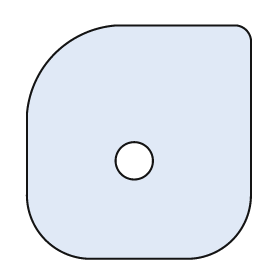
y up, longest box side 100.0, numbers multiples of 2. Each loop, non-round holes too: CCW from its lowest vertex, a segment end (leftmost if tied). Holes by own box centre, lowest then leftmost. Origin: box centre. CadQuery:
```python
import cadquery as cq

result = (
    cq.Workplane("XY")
    .moveTo(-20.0, -50.0)
    .lineTo(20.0, -50.0)
    .threePointArc((40.0, -42.0), (48.0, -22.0))
    .lineTo(48.0, 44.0)
    .threePointArc((46.0, 48.0), (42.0, 50.0))
    .lineTo(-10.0, 50.0)
    .threePointArc((-36.0, 38.0), (-48.0, 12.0))
    .lineTo(-48.0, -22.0)
    .threePointArc((-40.0, -42.0), (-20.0, -50.0))
    .close()
    .moveTo(-2.0, -8.0)
    .circle(8.0)
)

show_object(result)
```